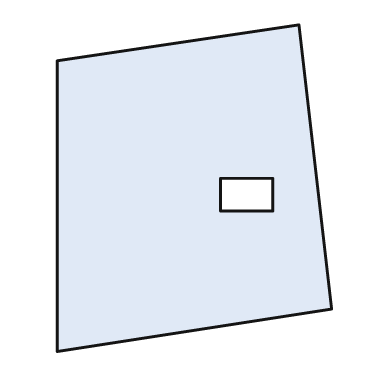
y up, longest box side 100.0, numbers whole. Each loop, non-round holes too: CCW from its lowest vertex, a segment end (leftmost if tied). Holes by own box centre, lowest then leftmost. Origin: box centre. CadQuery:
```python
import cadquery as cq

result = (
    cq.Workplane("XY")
    .moveTo(-42.0, -50.0)
    .lineTo(42.0, -37.0)
    .lineTo(32.0, 50.0)
    .lineTo(-42.0, 39.0)
    .close()
    .moveTo(8.0, -7.0)
    .lineTo(24.0, -7.0)
    .lineTo(24.0, 3.0)
    .lineTo(8.0, 3.0)
    .close()
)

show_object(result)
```